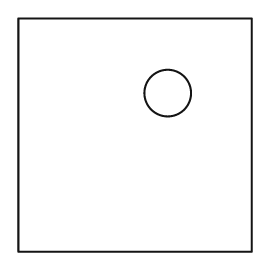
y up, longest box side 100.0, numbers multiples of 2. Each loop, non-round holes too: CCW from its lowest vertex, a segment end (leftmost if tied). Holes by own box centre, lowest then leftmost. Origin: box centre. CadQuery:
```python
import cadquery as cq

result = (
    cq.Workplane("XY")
    .moveTo(-50.0, -50.0)
    .lineTo(50.0, -50.0)
    .lineTo(50.0, 50.0)
    .lineTo(-50.0, 50.0)
    .close()
    .moveTo(14.0, 18.0)
    .circle(10.0)
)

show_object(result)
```